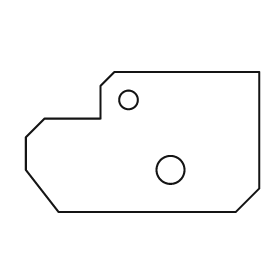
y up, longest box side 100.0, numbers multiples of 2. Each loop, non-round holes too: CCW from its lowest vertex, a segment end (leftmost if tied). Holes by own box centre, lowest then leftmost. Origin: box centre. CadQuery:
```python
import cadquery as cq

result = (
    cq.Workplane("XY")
    .moveTo(-36.0, -30.0)
    .lineTo(40.0, -30.0)
    .lineTo(50.0, -20.0)
    .lineTo(50.0, 30.0)
    .lineTo(-12.0, 30.0)
    .lineTo(-18.0, 24.0)
    .lineTo(-18.0, 10.0)
    .lineTo(-42.0, 10.0)
    .lineTo(-50.0, 2.0)
    .lineTo(-50.0, -12.0)
    .close()
    .moveTo(12.0, -12.0)
    .circle(6.0)
    .moveTo(-6.0, 18.0)
    .circle(4.0)
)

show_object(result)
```